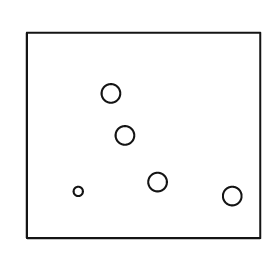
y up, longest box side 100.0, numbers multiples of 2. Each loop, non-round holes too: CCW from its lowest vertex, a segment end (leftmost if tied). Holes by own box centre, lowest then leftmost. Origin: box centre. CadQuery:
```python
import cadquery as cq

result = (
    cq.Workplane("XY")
    .moveTo(-50.0, -44.0)
    .lineTo(50.0, -44.0)
    .lineTo(50.0, 44.0)
    .lineTo(-50.0, 44.0)
    .close()
    .moveTo(38.0, -26.0)
    .circle(4.0)
    .moveTo(-28.0, -24.0)
    .circle(2.0)
    .moveTo(6.0, -20.0)
    .circle(4.0)
    .moveTo(-8.0, 0.0)
    .circle(4.0)
    .moveTo(-14.0, 18.0)
    .circle(4.0)
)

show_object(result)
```